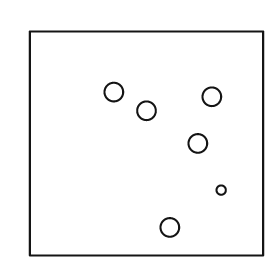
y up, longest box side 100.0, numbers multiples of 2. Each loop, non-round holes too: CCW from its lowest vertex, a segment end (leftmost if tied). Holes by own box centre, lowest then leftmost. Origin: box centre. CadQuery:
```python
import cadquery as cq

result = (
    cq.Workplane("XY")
    .moveTo(-50.0, -48.0)
    .lineTo(50.0, -48.0)
    .lineTo(50.0, 48.0)
    .lineTo(-50.0, 48.0)
    .close()
    .moveTo(10.0, -36.0)
    .circle(4.0)
    .moveTo(32.0, -20.0)
    .circle(2.0)
    .moveTo(22.0, 0.0)
    .circle(4.0)
    .moveTo(0.0, 14.0)
    .circle(4.0)
    .moveTo(28.0, 20.0)
    .circle(4.0)
    .moveTo(-14.0, 22.0)
    .circle(4.0)
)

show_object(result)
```